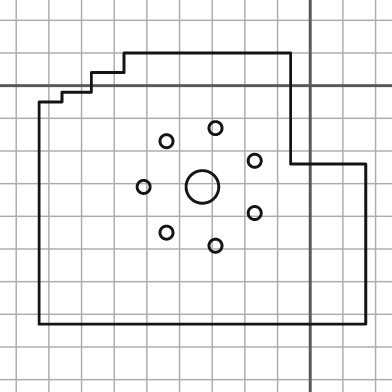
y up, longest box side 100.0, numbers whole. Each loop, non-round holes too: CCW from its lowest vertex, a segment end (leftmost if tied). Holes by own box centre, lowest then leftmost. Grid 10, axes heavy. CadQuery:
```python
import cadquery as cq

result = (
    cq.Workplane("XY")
    .moveTo(-83.0, -73.0)
    .lineTo(17.0, -73.0)
    .lineTo(17.0, -24.0)
    .lineTo(-6.0, -24.0)
    .lineTo(-6.0, 10.0)
    .lineTo(-57.0, 10.0)
    .lineTo(-57.0, 4.0)
    .lineTo(-67.0, 4.0)
    .lineTo(-67.0, -2.0)
    .lineTo(-76.0, -2.0)
    .lineTo(-76.0, -5.0)
    .lineTo(-83.0, -5.0)
    .close()
    .moveTo(-29.0, -49.0)
    .circle(2.0)
    .moveTo(-44.0, -45.0)
    .circle(2.0)
    .moveTo(-17.0, -39.0)
    .circle(2.0)
    .moveTo(-51.0, -31.0)
    .circle(2.0)
    .moveTo(-33.0, -31.0)
    .circle(5.0)
    .moveTo(-17.0, -23.0)
    .circle(2.0)
    .moveTo(-44.0, -17.0)
    .circle(2.0)
    .moveTo(-29.0, -13.0)
    .circle(2.0)
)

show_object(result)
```